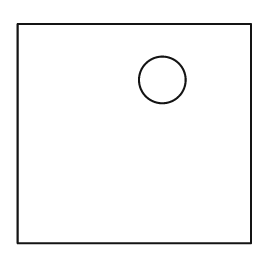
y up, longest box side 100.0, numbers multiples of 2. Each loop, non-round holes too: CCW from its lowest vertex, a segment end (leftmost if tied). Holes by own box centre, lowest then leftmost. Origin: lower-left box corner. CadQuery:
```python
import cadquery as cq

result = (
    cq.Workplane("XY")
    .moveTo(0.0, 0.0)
    .lineTo(100.0, 0.0)
    .lineTo(100.0, 94.0)
    .lineTo(0.0, 94.0)
    .close()
    .moveTo(62.0, 70.0)
    .circle(10.0)
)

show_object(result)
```